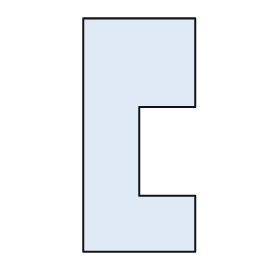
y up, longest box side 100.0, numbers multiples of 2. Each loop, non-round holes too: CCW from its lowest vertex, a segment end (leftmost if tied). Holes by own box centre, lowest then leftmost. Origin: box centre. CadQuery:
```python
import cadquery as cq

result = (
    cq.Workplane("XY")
    .moveTo(-24.0, -50.0)
    .lineTo(24.0, -50.0)
    .lineTo(24.0, -26.0)
    .lineTo(0.0, -26.0)
    .lineTo(0.0, 12.0)
    .lineTo(24.0, 12.0)
    .lineTo(24.0, 50.0)
    .lineTo(-24.0, 50.0)
    .close()
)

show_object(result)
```